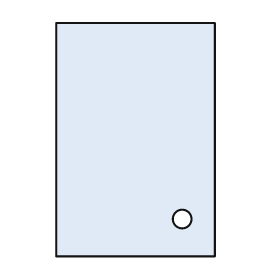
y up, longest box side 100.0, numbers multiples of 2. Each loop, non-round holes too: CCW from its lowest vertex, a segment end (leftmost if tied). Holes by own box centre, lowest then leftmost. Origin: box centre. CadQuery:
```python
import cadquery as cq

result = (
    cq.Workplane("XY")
    .moveTo(-34.0, -50.0)
    .lineTo(34.0, -50.0)
    .lineTo(34.0, 50.0)
    .lineTo(-34.0, 50.0)
    .close()
    .moveTo(20.0, -34.0)
    .circle(4.0)
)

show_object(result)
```